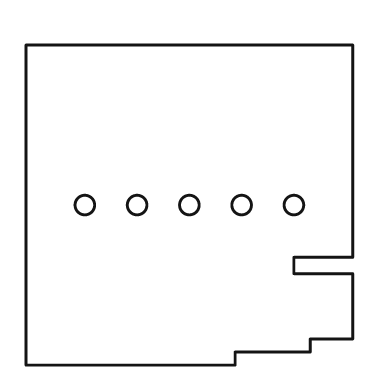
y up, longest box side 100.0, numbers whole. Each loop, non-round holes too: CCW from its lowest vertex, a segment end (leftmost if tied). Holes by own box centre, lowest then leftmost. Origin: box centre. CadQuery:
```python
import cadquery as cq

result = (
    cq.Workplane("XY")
    .moveTo(-50.0, -49.0)
    .lineTo(14.0, -49.0)
    .lineTo(14.0, -45.0)
    .lineTo(37.0, -45.0)
    .lineTo(37.0, -41.0)
    .lineTo(50.0, -41.0)
    .lineTo(50.0, -21.0)
    .lineTo(32.0, -21.0)
    .lineTo(32.0, -16.0)
    .lineTo(50.0, -16.0)
    .lineTo(50.0, 49.0)
    .lineTo(-50.0, 49.0)
    .close()
    .moveTo(-32.0, 0.0)
    .circle(3.0)
    .moveTo(-16.0, 0.0)
    .circle(3.0)
    .moveTo(0.0, 0.0)
    .circle(3.0)
    .moveTo(16.0, 0.0)
    .circle(3.0)
    .moveTo(32.0, 0.0)
    .circle(3.0)
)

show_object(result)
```